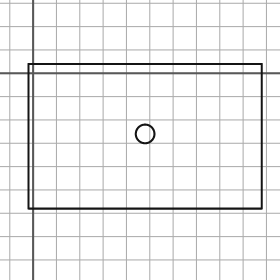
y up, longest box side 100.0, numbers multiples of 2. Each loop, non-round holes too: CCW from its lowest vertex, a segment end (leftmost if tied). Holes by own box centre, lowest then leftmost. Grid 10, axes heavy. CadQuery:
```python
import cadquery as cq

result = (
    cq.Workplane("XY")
    .moveTo(-2.0, -58.0)
    .lineTo(98.0, -58.0)
    .lineTo(98.0, 4.0)
    .lineTo(-2.0, 4.0)
    .close()
    .moveTo(48.0, -26.0)
    .circle(4.0)
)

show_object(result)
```